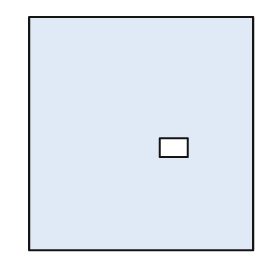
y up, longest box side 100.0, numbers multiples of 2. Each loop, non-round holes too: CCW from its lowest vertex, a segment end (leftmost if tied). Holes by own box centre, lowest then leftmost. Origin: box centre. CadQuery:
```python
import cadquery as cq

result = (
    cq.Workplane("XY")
    .moveTo(-48.0, -50.0)
    .lineTo(48.0, -50.0)
    .lineTo(48.0, 50.0)
    .lineTo(-48.0, 50.0)
    .close()
    .moveTo(8.0, -10.0)
    .lineTo(20.0, -10.0)
    .lineTo(20.0, -2.0)
    .lineTo(8.0, -2.0)
    .close()
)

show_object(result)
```